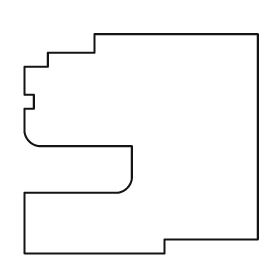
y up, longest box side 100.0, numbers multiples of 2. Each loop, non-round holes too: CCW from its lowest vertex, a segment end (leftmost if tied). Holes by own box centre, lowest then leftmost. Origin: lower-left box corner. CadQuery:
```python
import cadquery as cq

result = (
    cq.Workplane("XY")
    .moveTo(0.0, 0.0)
    .lineTo(60.0, 0.0)
    .lineTo(60.0, 6.0)
    .lineTo(100.0, 6.0)
    .lineTo(100.0, 94.0)
    .lineTo(30.0, 94.0)
    .lineTo(30.0, 86.0)
    .lineTo(10.0, 86.0)
    .lineTo(10.0, 80.0)
    .lineTo(0.0, 80.0)
    .lineTo(0.0, 68.0)
    .lineTo(4.0, 68.0)
    .lineTo(4.0, 62.0)
    .lineTo(0.0, 62.0)
    .lineTo(0.0, 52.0)
    .threePointArc((2.0, 48.0), (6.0, 46.0))
    .lineTo(46.0, 46.0)
    .lineTo(46.0, 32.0)
    .threePointArc((44.0, 28.0), (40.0, 26.0))
    .lineTo(0.0, 26.0)
    .close()
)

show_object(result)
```